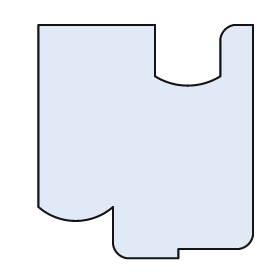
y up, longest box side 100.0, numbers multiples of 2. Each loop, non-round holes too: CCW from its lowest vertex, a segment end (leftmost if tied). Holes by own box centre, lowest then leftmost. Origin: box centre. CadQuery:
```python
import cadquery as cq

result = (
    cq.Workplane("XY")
    .moveTo(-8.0, -50.0)
    .lineTo(14.0, -50.0)
    .lineTo(14.0, -46.0)
    .lineTo(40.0, -46.0)
    .threePointArc((44.0, -44.0), (46.0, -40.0))
    .lineTo(46.0, 50.0)
    .lineTo(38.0, 50.0)
    .threePointArc((34.0, 48.0), (32.0, 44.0))
    .lineTo(32.0, 28.0)
    .threePointArc((18.0, 24.0), (4.0, 28.0))
    .lineTo(4.0, 50.0)
    .lineTo(-46.0, 50.0)
    .lineTo(-46.0, -28.0)
    .threePointArc((-30.0, -34.0), (-14.0, -28.0))
    .lineTo(-14.0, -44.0)
    .threePointArc((-12.0, -48.0), (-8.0, -50.0))
    .close()
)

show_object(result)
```